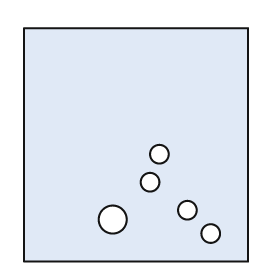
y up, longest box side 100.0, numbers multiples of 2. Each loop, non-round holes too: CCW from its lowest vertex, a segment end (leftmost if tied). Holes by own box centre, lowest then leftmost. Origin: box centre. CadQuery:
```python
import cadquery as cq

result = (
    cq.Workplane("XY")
    .moveTo(-48.0, -50.0)
    .lineTo(48.0, -50.0)
    .lineTo(48.0, 50.0)
    .lineTo(-48.0, 50.0)
    .close()
    .moveTo(32.0, -38.0)
    .circle(4.0)
    .moveTo(-10.0, -32.0)
    .circle(6.0)
    .moveTo(22.0, -28.0)
    .circle(4.0)
    .moveTo(6.0, -16.0)
    .circle(4.0)
    .moveTo(10.0, -4.0)
    .circle(4.0)
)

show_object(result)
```